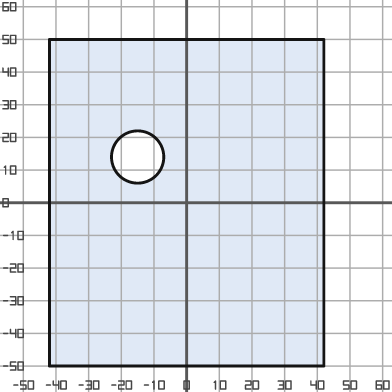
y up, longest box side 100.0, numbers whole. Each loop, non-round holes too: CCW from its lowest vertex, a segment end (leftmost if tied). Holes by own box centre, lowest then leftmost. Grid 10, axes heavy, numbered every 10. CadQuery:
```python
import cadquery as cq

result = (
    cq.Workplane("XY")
    .moveTo(-42.0, -50.0)
    .lineTo(42.0, -50.0)
    .lineTo(42.0, 50.0)
    .lineTo(-42.0, 50.0)
    .close()
    .moveTo(-15.0, 14.0)
    .circle(8.0)
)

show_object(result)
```